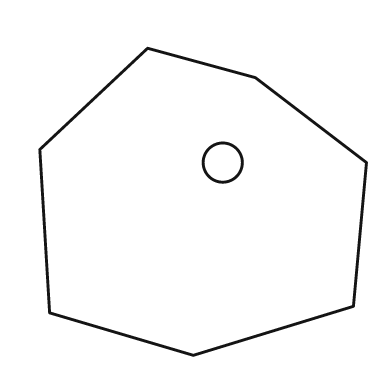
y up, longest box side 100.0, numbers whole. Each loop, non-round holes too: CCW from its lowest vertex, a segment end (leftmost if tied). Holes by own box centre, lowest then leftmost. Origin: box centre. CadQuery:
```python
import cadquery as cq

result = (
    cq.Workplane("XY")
    .moveTo(-3.0, -47.0)
    .lineTo(46.0, -32.0)
    .lineTo(50.0, 12.0)
    .lineTo(16.0, 38.0)
    .lineTo(-17.0, 47.0)
    .lineTo(-50.0, 16.0)
    .lineTo(-47.0, -34.0)
    .close()
    .moveTo(6.0, 12.0)
    .circle(6.0)
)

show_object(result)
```